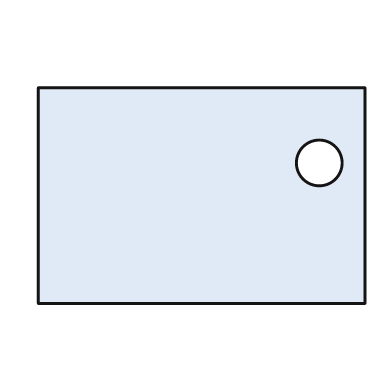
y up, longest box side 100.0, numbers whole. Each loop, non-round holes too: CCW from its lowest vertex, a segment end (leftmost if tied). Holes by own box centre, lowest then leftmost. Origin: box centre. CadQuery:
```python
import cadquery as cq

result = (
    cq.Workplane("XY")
    .moveTo(-50.0, -33.0)
    .lineTo(50.0, -33.0)
    .lineTo(50.0, 33.0)
    .lineTo(-50.0, 33.0)
    .close()
    .moveTo(36.0, 10.0)
    .circle(7.0)
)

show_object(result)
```